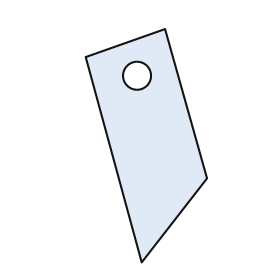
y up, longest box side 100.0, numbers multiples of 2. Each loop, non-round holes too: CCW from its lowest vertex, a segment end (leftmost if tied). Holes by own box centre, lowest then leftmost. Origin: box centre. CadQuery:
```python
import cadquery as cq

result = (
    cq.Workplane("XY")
    .moveTo(-2.0, -50.0)
    .lineTo(26.0, -14.0)
    .lineTo(8.0, 50.0)
    .lineTo(-26.0, 38.0)
    .close()
    .moveTo(-4.0, 30.0)
    .circle(6.0)
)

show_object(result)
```